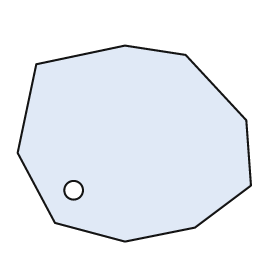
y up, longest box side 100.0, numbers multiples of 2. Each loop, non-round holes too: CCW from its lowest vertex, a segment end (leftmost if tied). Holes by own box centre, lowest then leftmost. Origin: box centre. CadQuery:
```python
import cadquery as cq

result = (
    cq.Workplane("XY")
    .moveTo(-4.0, -42.0)
    .lineTo(26.0, -36.0)
    .lineTo(50.0, -18.0)
    .lineTo(48.0, 10.0)
    .lineTo(22.0, 38.0)
    .lineTo(-4.0, 42.0)
    .lineTo(-42.0, 34.0)
    .lineTo(-50.0, -4.0)
    .lineTo(-34.0, -34.0)
    .close()
    .moveTo(-26.0, -20.0)
    .circle(4.0)
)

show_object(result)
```